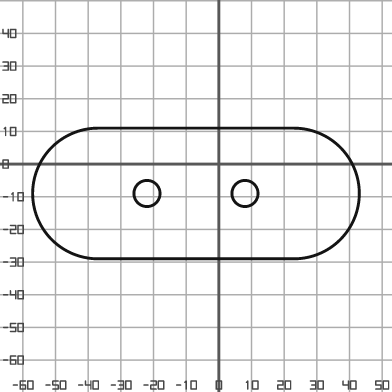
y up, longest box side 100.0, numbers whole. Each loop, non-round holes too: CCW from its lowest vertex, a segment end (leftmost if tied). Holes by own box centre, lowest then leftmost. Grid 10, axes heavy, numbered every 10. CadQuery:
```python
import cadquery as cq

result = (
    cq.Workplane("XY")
    .moveTo(-37.0, -29.0)
    .lineTo(23.0, -29.0)
    .threePointArc((43.0, -9.0), (23.0, 11.0))
    .lineTo(-37.0, 11.0)
    .threePointArc((-57.0, -9.0), (-37.0, -29.0))
    .close()
    .moveTo(-22.0, -9.0)
    .circle(4.0)
    .moveTo(8.0, -9.0)
    .circle(4.0)
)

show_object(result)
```